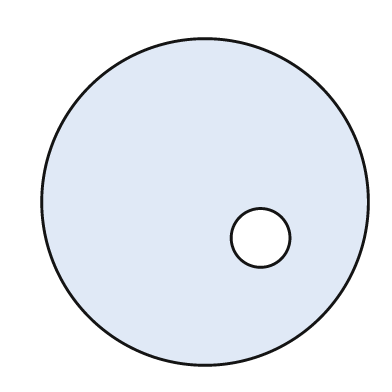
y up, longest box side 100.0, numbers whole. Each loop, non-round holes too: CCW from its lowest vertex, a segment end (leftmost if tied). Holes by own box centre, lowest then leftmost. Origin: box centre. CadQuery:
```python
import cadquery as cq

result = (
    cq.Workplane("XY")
    .moveTo(0.0, 0.0)
    .circle(50.0)
    .moveTo(17.0, -11.0)
    .circle(9.0)
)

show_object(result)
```